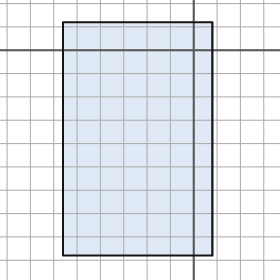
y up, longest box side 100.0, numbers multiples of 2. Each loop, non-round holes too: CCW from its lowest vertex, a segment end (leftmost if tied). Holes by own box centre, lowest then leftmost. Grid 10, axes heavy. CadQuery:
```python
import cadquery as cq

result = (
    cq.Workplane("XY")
    .moveTo(-56.0, -88.0)
    .lineTo(8.0, -88.0)
    .lineTo(8.0, 12.0)
    .lineTo(-56.0, 12.0)
    .close()
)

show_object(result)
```